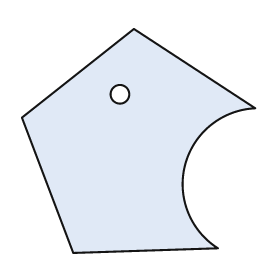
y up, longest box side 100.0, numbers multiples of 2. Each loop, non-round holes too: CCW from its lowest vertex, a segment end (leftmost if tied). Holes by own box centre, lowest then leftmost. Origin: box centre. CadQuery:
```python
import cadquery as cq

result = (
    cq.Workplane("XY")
    .moveTo(-28.0, -48.0)
    .lineTo(34.0, -46.0)
    .threePointArc((20.0, -10.0), (50.0, 14.0))
    .lineTo(-2.0, 48.0)
    .lineTo(-50.0, 10.0)
    .close()
    .moveTo(-8.0, 20.0)
    .circle(4.0)
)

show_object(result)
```